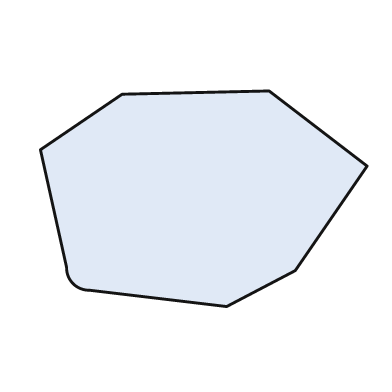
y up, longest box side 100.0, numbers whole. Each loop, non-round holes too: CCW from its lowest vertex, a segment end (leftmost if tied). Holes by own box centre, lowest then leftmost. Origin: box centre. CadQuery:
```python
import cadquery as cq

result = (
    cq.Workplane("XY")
    .moveTo(7.0, -33.0)
    .lineTo(28.0, -22.0)
    .lineTo(50.0, 10.0)
    .lineTo(20.0, 33.0)
    .lineTo(-25.0, 32.0)
    .lineTo(-50.0, 15.0)
    .lineTo(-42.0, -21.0)
    .threePointArc((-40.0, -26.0), (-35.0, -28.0))
    .close()
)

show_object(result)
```